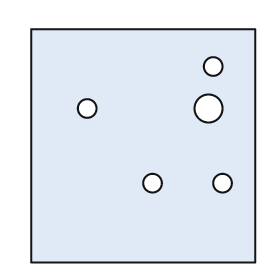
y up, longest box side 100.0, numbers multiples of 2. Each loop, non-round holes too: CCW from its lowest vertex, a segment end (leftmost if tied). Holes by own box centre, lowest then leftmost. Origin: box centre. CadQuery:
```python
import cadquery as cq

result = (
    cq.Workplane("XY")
    .moveTo(-48.0, -50.0)
    .lineTo(48.0, -50.0)
    .lineTo(48.0, 50.0)
    .lineTo(-48.0, 50.0)
    .close()
    .moveTo(4.0, -16.0)
    .circle(4.0)
    .moveTo(34.0, -16.0)
    .circle(4.0)
    .moveTo(-24.0, 16.0)
    .circle(4.0)
    .moveTo(28.0, 16.0)
    .circle(6.0)
    .moveTo(30.0, 34.0)
    .circle(4.0)
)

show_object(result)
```